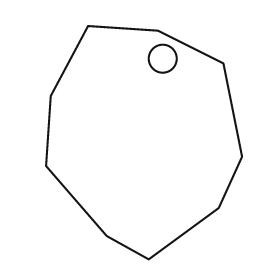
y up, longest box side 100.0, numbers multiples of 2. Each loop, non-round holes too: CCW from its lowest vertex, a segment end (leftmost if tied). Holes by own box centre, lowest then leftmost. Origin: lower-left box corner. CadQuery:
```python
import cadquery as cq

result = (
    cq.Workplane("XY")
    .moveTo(44.0, 0.0)
    .lineTo(74.0, 22.0)
    .lineTo(84.0, 44.0)
    .lineTo(76.0, 84.0)
    .lineTo(48.0, 98.0)
    .lineTo(18.0, 100.0)
    .lineTo(2.0, 70.0)
    .lineTo(0.0, 40.0)
    .lineTo(26.0, 10.0)
    .close()
    .moveTo(50.0, 86.0)
    .circle(6.0)
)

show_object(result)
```